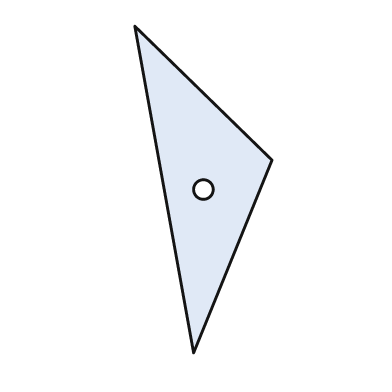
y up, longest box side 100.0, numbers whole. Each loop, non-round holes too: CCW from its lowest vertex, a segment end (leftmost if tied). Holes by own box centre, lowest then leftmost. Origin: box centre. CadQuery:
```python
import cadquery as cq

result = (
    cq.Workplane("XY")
    .moveTo(-3.0, -50.0)
    .lineTo(21.0, 9.0)
    .lineTo(-21.0, 50.0)
    .close()
    .moveTo(0.0, 0.0)
    .circle(3.0)
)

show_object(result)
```